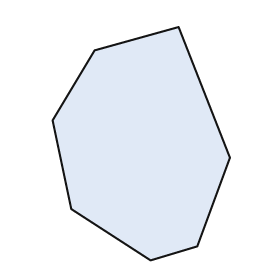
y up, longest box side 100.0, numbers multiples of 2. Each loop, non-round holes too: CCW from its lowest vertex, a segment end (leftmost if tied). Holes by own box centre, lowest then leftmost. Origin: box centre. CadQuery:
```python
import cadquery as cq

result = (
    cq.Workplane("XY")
    .moveTo(4.0, -50.0)
    .lineTo(24.0, -44.0)
    .lineTo(38.0, -6.0)
    .lineTo(16.0, 50.0)
    .lineTo(-20.0, 40.0)
    .lineTo(-38.0, 10.0)
    .lineTo(-30.0, -28.0)
    .close()
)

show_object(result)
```